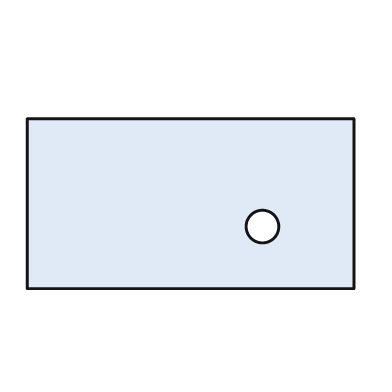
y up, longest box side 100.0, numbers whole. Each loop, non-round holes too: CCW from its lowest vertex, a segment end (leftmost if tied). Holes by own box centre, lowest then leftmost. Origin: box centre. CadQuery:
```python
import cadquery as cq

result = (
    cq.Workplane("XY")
    .moveTo(-50.0, -26.0)
    .lineTo(50.0, -26.0)
    .lineTo(50.0, 26.0)
    .lineTo(-50.0, 26.0)
    .close()
    .moveTo(22.0, -7.0)
    .circle(5.0)
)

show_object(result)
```